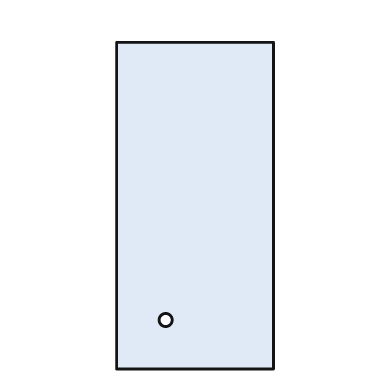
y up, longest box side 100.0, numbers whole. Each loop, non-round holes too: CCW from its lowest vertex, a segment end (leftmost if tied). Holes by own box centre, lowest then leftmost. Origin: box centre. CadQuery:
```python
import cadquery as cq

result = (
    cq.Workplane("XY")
    .moveTo(-24.0, -50.0)
    .lineTo(24.0, -50.0)
    .lineTo(24.0, 50.0)
    .lineTo(-24.0, 50.0)
    .close()
    .moveTo(-9.0, -35.0)
    .circle(2.0)
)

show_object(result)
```